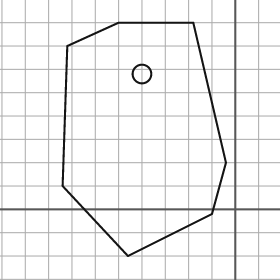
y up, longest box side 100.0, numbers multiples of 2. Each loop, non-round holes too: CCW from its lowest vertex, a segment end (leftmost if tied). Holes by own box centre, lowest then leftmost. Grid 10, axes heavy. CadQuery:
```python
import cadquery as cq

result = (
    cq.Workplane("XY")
    .moveTo(-46.0, -20.0)
    .lineTo(-10.0, -2.0)
    .lineTo(-4.0, 20.0)
    .lineTo(-18.0, 80.0)
    .lineTo(-50.0, 80.0)
    .lineTo(-72.0, 70.0)
    .lineTo(-74.0, 10.0)
    .close()
    .moveTo(-40.0, 58.0)
    .circle(4.0)
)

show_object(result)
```